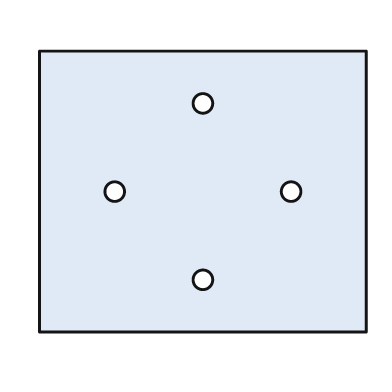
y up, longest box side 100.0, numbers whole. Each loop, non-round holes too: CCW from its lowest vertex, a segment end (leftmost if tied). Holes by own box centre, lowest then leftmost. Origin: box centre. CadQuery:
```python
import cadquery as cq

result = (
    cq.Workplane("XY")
    .moveTo(-50.0, -43.0)
    .lineTo(50.0, -43.0)
    .lineTo(50.0, 43.0)
    .lineTo(-50.0, 43.0)
    .close()
    .moveTo(0.0, -27.0)
    .circle(3.0)
    .moveTo(-27.0, 0.0)
    .circle(3.0)
    .moveTo(27.0, 0.0)
    .circle(3.0)
    .moveTo(0.0, 27.0)
    .circle(3.0)
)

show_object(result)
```